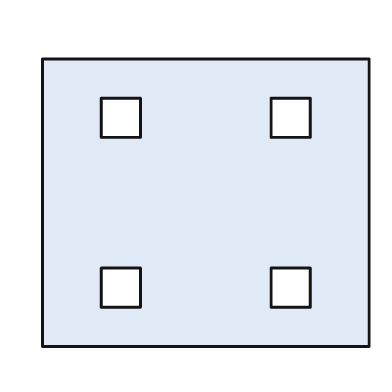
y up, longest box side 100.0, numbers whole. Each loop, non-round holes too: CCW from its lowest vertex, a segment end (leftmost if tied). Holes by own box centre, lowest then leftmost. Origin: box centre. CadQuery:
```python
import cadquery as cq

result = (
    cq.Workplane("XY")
    .moveTo(-50.0, -44.0)
    .lineTo(50.0, -44.0)
    .lineTo(50.0, 44.0)
    .lineTo(-50.0, 44.0)
    .close()
    .moveTo(-32.0, -32.0)
    .lineTo(-20.0, -32.0)
    .lineTo(-20.0, -20.0)
    .lineTo(-32.0, -20.0)
    .close()
    .moveTo(20.0, -32.0)
    .lineTo(32.0, -32.0)
    .lineTo(32.0, -20.0)
    .lineTo(20.0, -20.0)
    .close()
    .moveTo(-32.0, 20.0)
    .lineTo(-20.0, 20.0)
    .lineTo(-20.0, 32.0)
    .lineTo(-32.0, 32.0)
    .close()
    .moveTo(20.0, 20.0)
    .lineTo(32.0, 20.0)
    .lineTo(32.0, 32.0)
    .lineTo(20.0, 32.0)
    .close()
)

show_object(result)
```